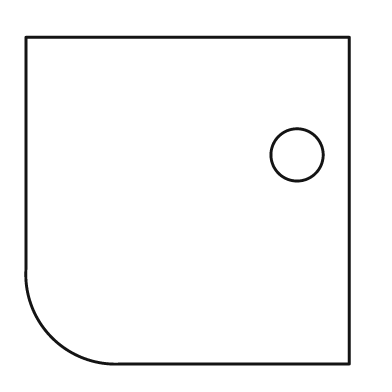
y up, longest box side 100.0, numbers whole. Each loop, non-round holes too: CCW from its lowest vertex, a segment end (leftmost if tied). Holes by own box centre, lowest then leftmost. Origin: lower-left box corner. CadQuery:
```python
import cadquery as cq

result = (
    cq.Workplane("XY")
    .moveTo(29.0, 0.0)
    .lineTo(99.0, 0.0)
    .lineTo(99.0, 100.0)
    .lineTo(0.0, 100.0)
    .lineTo(0.0, 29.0)
    .threePointArc((8.0, 8.0), (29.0, 0.0))
    .close()
    .moveTo(83.0, 64.0)
    .circle(8.0)
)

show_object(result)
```